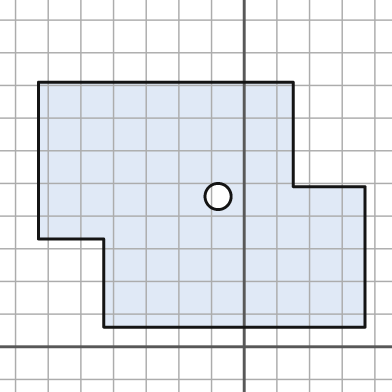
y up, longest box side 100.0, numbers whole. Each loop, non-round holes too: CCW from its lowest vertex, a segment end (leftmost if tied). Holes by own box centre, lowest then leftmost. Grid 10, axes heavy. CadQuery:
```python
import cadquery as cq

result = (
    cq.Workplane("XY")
    .moveTo(-43.0, 6.0)
    .lineTo(37.0, 6.0)
    .lineTo(37.0, 49.0)
    .lineTo(15.0, 49.0)
    .lineTo(15.0, 81.0)
    .lineTo(-63.0, 81.0)
    .lineTo(-63.0, 33.0)
    .lineTo(-43.0, 33.0)
    .close()
    .moveTo(-8.0, 46.0)
    .circle(4.0)
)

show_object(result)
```